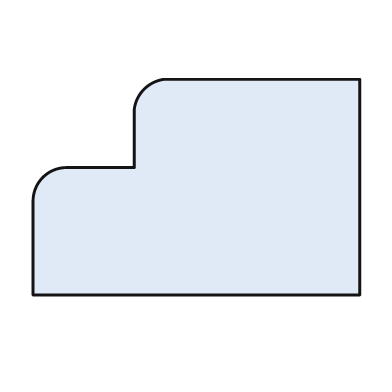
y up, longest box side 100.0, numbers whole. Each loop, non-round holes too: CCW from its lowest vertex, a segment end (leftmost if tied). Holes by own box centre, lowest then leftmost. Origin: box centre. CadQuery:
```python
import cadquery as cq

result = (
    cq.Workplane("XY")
    .moveTo(-50.0, -33.0)
    .lineTo(50.0, -33.0)
    .lineTo(50.0, 33.0)
    .lineTo(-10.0, 33.0)
    .threePointArc((-16.0, 30.0), (-19.0, 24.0))
    .lineTo(-19.0, 6.0)
    .lineTo(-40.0, 6.0)
    .threePointArc((-47.0, 3.0), (-50.0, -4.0))
    .close()
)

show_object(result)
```